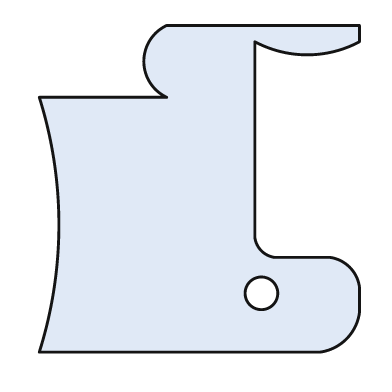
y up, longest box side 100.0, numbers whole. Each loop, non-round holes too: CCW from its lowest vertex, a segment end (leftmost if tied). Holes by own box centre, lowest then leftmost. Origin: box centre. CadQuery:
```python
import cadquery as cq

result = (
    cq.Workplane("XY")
    .moveTo(-49.0, -50.0)
    .lineTo(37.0, -50.0)
    .threePointArc((45.0, -46.0), (49.0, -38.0))
    .lineTo(49.0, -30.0)
    .threePointArc((46.0, -24.0), (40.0, -21.0))
    .lineTo(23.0, -21.0)
    .threePointArc((19.0, -19.0), (17.0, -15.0))
    .lineTo(17.0, 45.0)
    .threePointArc((33.0, 41.0), (49.0, 45.0))
    .lineTo(49.0, 50.0)
    .lineTo(-10.0, 50.0)
    .threePointArc((-17.0, 39.0), (-10.0, 28.0))
    .lineTo(-49.0, 28.0)
    .threePointArc((-43.0, -11.0), (-49.0, -50.0))
    .close()
    .moveTo(19.0, -32.0)
    .circle(5.0)
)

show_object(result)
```